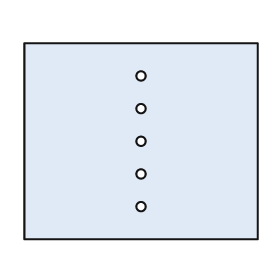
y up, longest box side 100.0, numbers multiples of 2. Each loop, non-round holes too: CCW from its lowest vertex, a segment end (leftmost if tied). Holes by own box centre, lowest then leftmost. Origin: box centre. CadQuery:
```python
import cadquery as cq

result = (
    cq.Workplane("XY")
    .moveTo(-50.0, -42.0)
    .lineTo(50.0, -42.0)
    .lineTo(50.0, 42.0)
    .lineTo(-50.0, 42.0)
    .close()
    .moveTo(0.0, -28.0)
    .circle(2.0)
    .moveTo(0.0, -14.0)
    .circle(2.0)
    .moveTo(0.0, 0.0)
    .circle(2.0)
    .moveTo(0.0, 14.0)
    .circle(2.0)
    .moveTo(0.0, 28.0)
    .circle(2.0)
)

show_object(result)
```